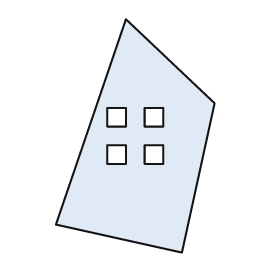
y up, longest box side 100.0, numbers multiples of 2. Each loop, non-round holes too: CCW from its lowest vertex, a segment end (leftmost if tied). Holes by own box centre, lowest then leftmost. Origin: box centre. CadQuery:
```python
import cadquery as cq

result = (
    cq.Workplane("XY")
    .moveTo(20.0, -50.0)
    .lineTo(34.0, 14.0)
    .lineTo(-4.0, 50.0)
    .lineTo(-34.0, -38.0)
    .close()
    .moveTo(-12.0, -12.0)
    .lineTo(-4.0, -12.0)
    .lineTo(-4.0, -4.0)
    .lineTo(-12.0, -4.0)
    .close()
    .moveTo(4.0, -12.0)
    .lineTo(12.0, -12.0)
    .lineTo(12.0, -4.0)
    .lineTo(4.0, -4.0)
    .close()
    .moveTo(-12.0, 4.0)
    .lineTo(-4.0, 4.0)
    .lineTo(-4.0, 12.0)
    .lineTo(-12.0, 12.0)
    .close()
    .moveTo(4.0, 4.0)
    .lineTo(12.0, 4.0)
    .lineTo(12.0, 12.0)
    .lineTo(4.0, 12.0)
    .close()
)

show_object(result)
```